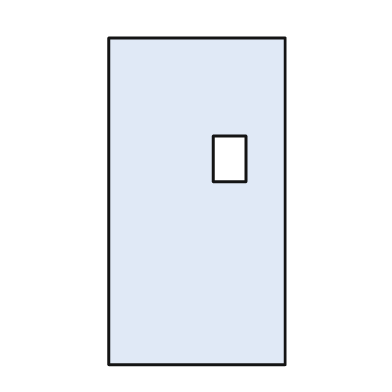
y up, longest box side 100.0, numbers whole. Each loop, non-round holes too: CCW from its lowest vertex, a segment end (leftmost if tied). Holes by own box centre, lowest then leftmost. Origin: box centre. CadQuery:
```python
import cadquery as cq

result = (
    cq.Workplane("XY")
    .moveTo(-27.0, -50.0)
    .lineTo(27.0, -50.0)
    .lineTo(27.0, 50.0)
    .lineTo(-27.0, 50.0)
    .close()
    .moveTo(5.0, 6.0)
    .lineTo(15.0, 6.0)
    .lineTo(15.0, 20.0)
    .lineTo(5.0, 20.0)
    .close()
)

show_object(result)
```